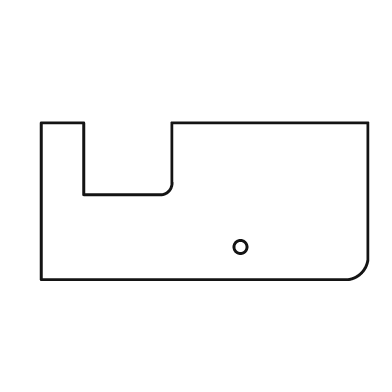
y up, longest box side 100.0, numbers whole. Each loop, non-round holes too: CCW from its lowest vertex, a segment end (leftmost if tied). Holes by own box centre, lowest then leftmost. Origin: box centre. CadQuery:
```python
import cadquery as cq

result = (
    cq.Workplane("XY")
    .moveTo(-50.0, -24.0)
    .lineTo(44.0, -24.0)
    .threePointArc((48.0, -22.0), (50.0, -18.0))
    .lineTo(50.0, 24.0)
    .lineTo(-10.0, 24.0)
    .lineTo(-10.0, 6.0)
    .threePointArc((-11.0, 3.0), (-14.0, 2.0))
    .lineTo(-37.0, 2.0)
    .lineTo(-37.0, 24.0)
    .lineTo(-50.0, 24.0)
    .close()
    .moveTo(11.0, -14.0)
    .circle(2.0)
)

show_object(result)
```